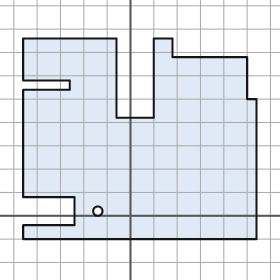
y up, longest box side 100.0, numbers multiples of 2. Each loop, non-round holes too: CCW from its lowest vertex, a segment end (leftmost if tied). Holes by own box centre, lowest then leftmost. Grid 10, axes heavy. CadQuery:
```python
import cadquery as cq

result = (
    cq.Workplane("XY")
    .moveTo(-46.0, -10.0)
    .lineTo(54.0, -10.0)
    .lineTo(54.0, 50.0)
    .lineTo(50.0, 50.0)
    .lineTo(50.0, 68.0)
    .lineTo(18.0, 68.0)
    .lineTo(18.0, 76.0)
    .lineTo(10.0, 76.0)
    .lineTo(10.0, 42.0)
    .lineTo(-6.0, 42.0)
    .lineTo(-6.0, 76.0)
    .lineTo(-46.0, 76.0)
    .lineTo(-46.0, 58.0)
    .lineTo(-26.0, 58.0)
    .lineTo(-26.0, 54.0)
    .lineTo(-46.0, 54.0)
    .lineTo(-46.0, 8.0)
    .lineTo(-24.0, 8.0)
    .lineTo(-24.0, -4.0)
    .lineTo(-46.0, -4.0)
    .close()
    .moveTo(-14.0, 2.0)
    .circle(2.0)
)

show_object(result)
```